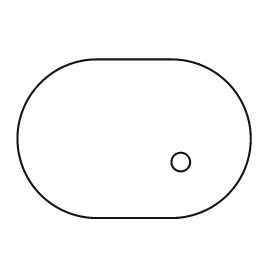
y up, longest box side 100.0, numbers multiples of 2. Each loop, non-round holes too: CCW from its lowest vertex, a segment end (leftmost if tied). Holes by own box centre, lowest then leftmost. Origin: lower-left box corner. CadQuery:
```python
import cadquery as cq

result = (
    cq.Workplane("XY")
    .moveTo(34.0, 0.0)
    .lineTo(66.0, 0.0)
    .threePointArc((100.0, 34.0), (66.0, 68.0))
    .lineTo(34.0, 68.0)
    .threePointArc((0.0, 34.0), (34.0, 0.0))
    .close()
    .moveTo(70.0, 24.0)
    .circle(4.0)
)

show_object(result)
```